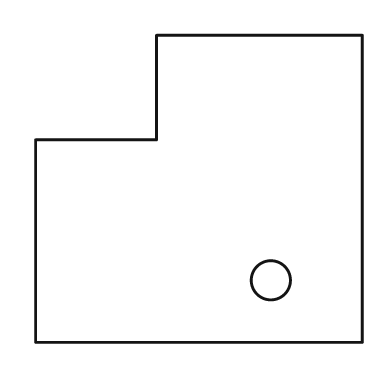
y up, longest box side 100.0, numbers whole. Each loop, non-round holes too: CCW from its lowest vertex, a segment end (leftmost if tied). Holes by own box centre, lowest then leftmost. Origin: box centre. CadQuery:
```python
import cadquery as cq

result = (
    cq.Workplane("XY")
    .moveTo(-50.0, -47.0)
    .lineTo(50.0, -47.0)
    .lineTo(50.0, 47.0)
    .lineTo(-13.0, 47.0)
    .lineTo(-13.0, 15.0)
    .lineTo(-50.0, 15.0)
    .close()
    .moveTo(22.0, -28.0)
    .circle(6.0)
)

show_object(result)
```